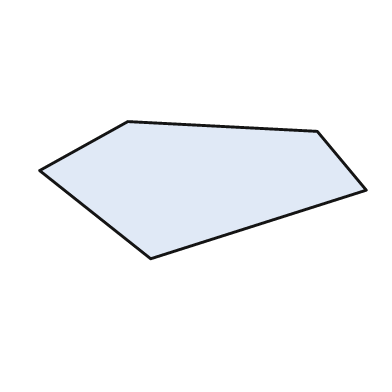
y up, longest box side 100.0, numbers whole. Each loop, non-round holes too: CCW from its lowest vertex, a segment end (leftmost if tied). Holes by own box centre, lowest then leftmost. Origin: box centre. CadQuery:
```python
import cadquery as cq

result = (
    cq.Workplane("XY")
    .moveTo(-16.0, -21.0)
    .lineTo(50.0, 0.0)
    .lineTo(35.0, 18.0)
    .lineTo(-23.0, 21.0)
    .lineTo(-50.0, 6.0)
    .close()
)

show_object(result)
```